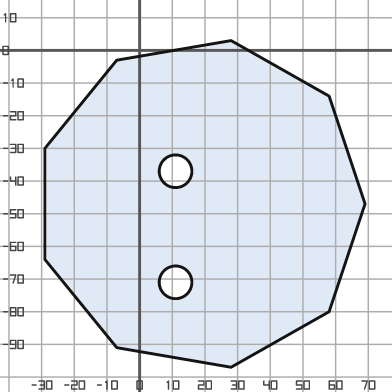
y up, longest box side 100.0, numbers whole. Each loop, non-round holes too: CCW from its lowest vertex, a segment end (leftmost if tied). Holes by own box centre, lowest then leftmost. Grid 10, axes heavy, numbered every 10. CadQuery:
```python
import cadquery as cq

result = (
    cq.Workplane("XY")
    .moveTo(28.0, -97.0)
    .lineTo(58.0, -80.0)
    .lineTo(69.0, -47.0)
    .lineTo(58.0, -14.0)
    .lineTo(28.0, 3.0)
    .lineTo(-7.0, -3.0)
    .lineTo(-29.0, -30.0)
    .lineTo(-29.0, -64.0)
    .lineTo(-7.0, -91.0)
    .close()
    .moveTo(11.0, -71.0)
    .circle(5.0)
    .moveTo(11.0, -37.0)
    .circle(5.0)
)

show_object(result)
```